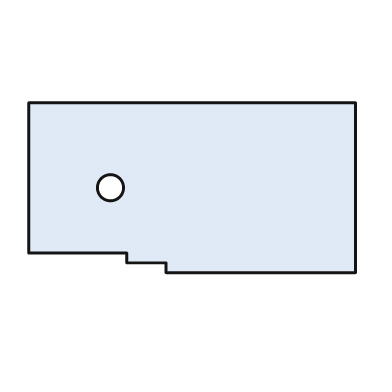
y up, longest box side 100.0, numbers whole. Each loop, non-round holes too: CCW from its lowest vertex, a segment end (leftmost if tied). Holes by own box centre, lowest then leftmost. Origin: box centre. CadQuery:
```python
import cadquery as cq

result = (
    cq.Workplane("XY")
    .moveTo(-8.0, -26.0)
    .lineTo(50.0, -26.0)
    .lineTo(50.0, 26.0)
    .lineTo(-50.0, 26.0)
    .lineTo(-50.0, -20.0)
    .lineTo(-20.0, -20.0)
    .lineTo(-20.0, -23.0)
    .lineTo(-8.0, -23.0)
    .close()
    .moveTo(-25.0, 0.0)
    .circle(4.0)
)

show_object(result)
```